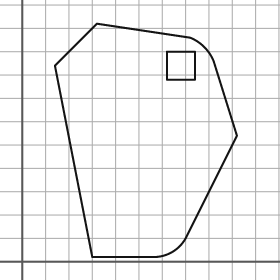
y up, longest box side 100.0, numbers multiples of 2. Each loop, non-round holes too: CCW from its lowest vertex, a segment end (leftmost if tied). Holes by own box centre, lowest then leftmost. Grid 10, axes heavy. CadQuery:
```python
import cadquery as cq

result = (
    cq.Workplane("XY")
    .moveTo(30.0, 2.0)
    .lineTo(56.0, 2.0)
    .threePointArc((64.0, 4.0), (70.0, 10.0))
    .lineTo(92.0, 54.0)
    .lineTo(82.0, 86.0)
    .threePointArc((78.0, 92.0), (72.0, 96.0))
    .lineTo(32.0, 102.0)
    .lineTo(14.0, 84.0)
    .close()
    .moveTo(62.0, 78.0)
    .lineTo(74.0, 78.0)
    .lineTo(74.0, 90.0)
    .lineTo(62.0, 90.0)
    .close()
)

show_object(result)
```